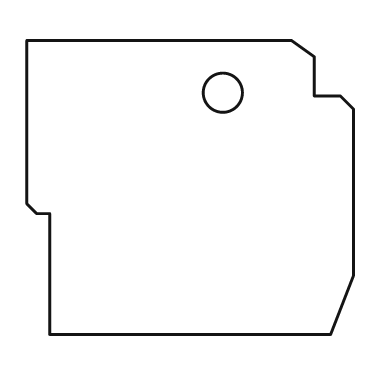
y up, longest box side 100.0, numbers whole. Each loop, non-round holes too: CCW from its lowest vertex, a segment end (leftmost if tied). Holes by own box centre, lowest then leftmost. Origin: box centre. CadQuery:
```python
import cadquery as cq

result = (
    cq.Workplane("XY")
    .moveTo(-43.0, -45.0)
    .lineTo(43.0, -45.0)
    .lineTo(50.0, -27.0)
    .lineTo(50.0, 24.0)
    .lineTo(46.0, 28.0)
    .lineTo(38.0, 28.0)
    .lineTo(38.0, 40.0)
    .lineTo(31.0, 45.0)
    .lineTo(-50.0, 45.0)
    .lineTo(-50.0, -5.0)
    .lineTo(-47.0, -8.0)
    .lineTo(-43.0, -8.0)
    .close()
    .moveTo(10.0, 29.0)
    .circle(6.0)
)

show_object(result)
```